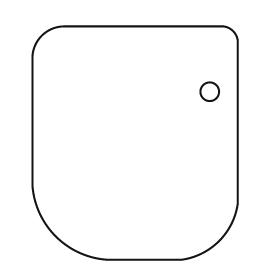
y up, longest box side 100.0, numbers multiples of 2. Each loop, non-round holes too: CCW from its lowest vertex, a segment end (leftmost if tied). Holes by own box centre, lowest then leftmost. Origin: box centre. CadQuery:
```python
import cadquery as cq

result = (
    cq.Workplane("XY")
    .moveTo(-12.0, -50.0)
    .lineTo(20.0, -50.0)
    .threePointArc((36.0, -42.0), (44.0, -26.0))
    .lineTo(44.0, 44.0)
    .threePointArc((42.0, 48.0), (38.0, 50.0))
    .lineTo(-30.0, 50.0)
    .threePointArc((-40.0, 46.0), (-44.0, 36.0))
    .lineTo(-44.0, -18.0)
    .threePointArc((-34.0, -40.0), (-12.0, -50.0))
    .close()
    .moveTo(32.0, 22.0)
    .circle(4.0)
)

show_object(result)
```